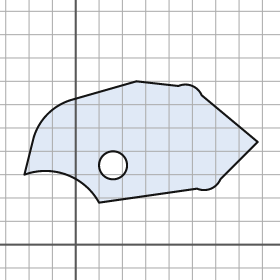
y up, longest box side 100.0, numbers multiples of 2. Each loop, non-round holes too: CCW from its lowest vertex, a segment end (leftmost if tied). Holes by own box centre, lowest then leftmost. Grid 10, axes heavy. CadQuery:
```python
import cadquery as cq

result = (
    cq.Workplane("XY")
    .moveTo(10.0, 18.0)
    .lineTo(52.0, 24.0)
    .threePointArc((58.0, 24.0), (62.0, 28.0))
    .lineTo(78.0, 44.0)
    .lineTo(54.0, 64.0)
    .threePointArc((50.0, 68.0), (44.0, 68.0))
    .lineTo(26.0, 70.0)
    .lineTo(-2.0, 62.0)
    .threePointArc((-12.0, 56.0), (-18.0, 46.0))
    .lineTo(-22.0, 30.0)
    .threePointArc((-4.0, 30.0), (10.0, 18.0))
    .close()
    .moveTo(16.0, 34.0)
    .circle(6.0)
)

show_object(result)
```